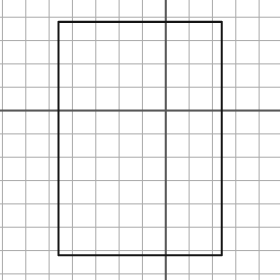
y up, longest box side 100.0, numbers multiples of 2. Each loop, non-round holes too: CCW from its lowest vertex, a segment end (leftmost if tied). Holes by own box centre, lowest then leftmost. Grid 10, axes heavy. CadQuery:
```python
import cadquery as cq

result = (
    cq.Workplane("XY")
    .moveTo(-46.0, -62.0)
    .lineTo(24.0, -62.0)
    .lineTo(24.0, 38.0)
    .lineTo(-46.0, 38.0)
    .close()
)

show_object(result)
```